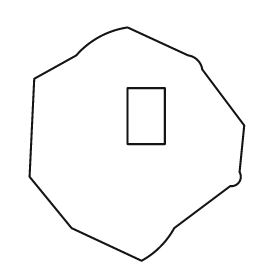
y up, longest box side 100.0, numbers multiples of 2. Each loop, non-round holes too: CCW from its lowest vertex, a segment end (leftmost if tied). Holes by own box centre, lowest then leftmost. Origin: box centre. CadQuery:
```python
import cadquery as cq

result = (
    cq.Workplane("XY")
    .moveTo(2.0, -50.0)
    .threePointArc((10.0, -44.0), (16.0, -36.0))
    .lineTo(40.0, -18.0)
    .threePointArc((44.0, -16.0), (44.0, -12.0))
    .lineTo(46.0, 8.0)
    .lineTo(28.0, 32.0)
    .threePointArc((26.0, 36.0), (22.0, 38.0))
    .lineTo(-4.0, 50.0)
    .threePointArc((-16.0, 46.0), (-26.0, 38.0))
    .lineTo(-44.0, 28.0)
    .lineTo(-46.0, -14.0)
    .lineTo(-28.0, -36.0)
    .close()
    .moveTo(-4.0, 0.0)
    .lineTo(12.0, 0.0)
    .lineTo(12.0, 24.0)
    .lineTo(-4.0, 24.0)
    .close()
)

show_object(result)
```